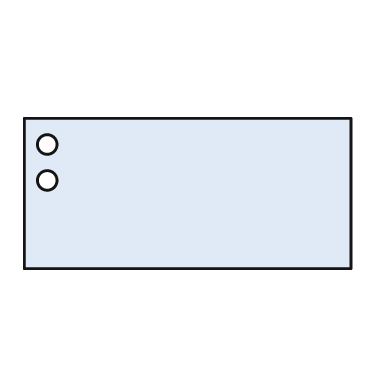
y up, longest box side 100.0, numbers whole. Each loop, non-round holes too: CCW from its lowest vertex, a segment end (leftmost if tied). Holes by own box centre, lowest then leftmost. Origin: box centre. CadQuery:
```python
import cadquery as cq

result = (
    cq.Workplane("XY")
    .moveTo(-50.0, -23.0)
    .lineTo(50.0, -23.0)
    .lineTo(50.0, 23.0)
    .lineTo(-50.0, 23.0)
    .close()
    .moveTo(-43.0, 4.0)
    .circle(3.0)
    .moveTo(-43.0, 15.0)
    .circle(3.0)
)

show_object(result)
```